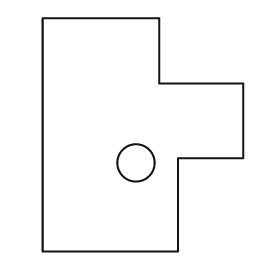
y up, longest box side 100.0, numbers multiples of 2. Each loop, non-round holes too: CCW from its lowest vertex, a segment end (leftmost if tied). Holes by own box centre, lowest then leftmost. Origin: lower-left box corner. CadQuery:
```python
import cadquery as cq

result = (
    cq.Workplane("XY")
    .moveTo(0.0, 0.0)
    .lineTo(58.0, 0.0)
    .lineTo(58.0, 40.0)
    .lineTo(86.0, 40.0)
    .lineTo(86.0, 72.0)
    .lineTo(50.0, 72.0)
    .lineTo(50.0, 100.0)
    .lineTo(0.0, 100.0)
    .close()
    .moveTo(40.0, 38.0)
    .circle(8.0)
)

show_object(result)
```